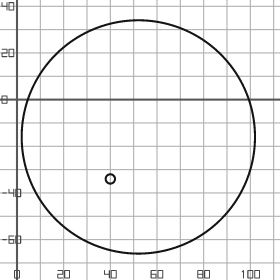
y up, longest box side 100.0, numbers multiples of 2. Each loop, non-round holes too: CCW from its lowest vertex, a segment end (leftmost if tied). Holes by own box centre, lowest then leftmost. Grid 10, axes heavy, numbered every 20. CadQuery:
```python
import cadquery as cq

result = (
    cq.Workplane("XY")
    .moveTo(52.0, -16.0)
    .circle(50.0)
    .moveTo(40.0, -34.0)
    .circle(2.0)
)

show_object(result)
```